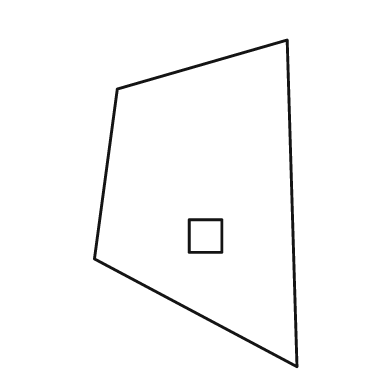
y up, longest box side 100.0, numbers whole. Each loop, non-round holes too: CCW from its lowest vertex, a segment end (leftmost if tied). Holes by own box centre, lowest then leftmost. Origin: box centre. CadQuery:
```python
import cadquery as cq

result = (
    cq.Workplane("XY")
    .moveTo(31.0, -50.0)
    .lineTo(28.0, 50.0)
    .lineTo(-24.0, 35.0)
    .lineTo(-31.0, -17.0)
    .close()
    .moveTo(-2.0, -15.0)
    .lineTo(8.0, -15.0)
    .lineTo(8.0, -5.0)
    .lineTo(-2.0, -5.0)
    .close()
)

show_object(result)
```